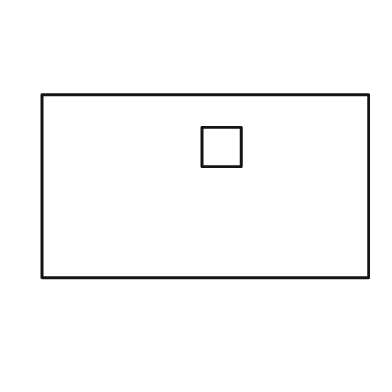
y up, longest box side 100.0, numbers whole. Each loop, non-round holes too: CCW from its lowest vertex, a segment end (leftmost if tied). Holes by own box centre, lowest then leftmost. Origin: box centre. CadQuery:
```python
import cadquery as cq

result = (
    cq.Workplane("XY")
    .moveTo(-50.0, -28.0)
    .lineTo(50.0, -28.0)
    .lineTo(50.0, 28.0)
    .lineTo(-50.0, 28.0)
    .close()
    .moveTo(-1.0, 6.0)
    .lineTo(11.0, 6.0)
    .lineTo(11.0, 18.0)
    .lineTo(-1.0, 18.0)
    .close()
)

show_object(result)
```